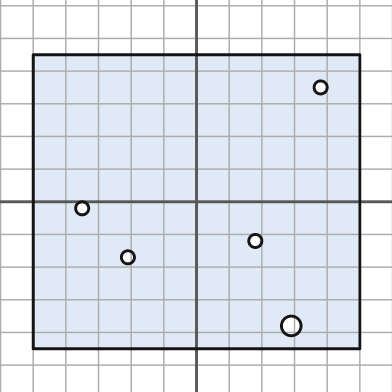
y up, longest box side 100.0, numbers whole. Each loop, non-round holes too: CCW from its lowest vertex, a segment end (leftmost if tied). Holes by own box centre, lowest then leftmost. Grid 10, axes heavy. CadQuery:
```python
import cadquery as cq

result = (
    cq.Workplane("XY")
    .moveTo(-50.0, -45.0)
    .lineTo(50.0, -45.0)
    .lineTo(50.0, 45.0)
    .lineTo(-50.0, 45.0)
    .close()
    .moveTo(29.0, -38.0)
    .circle(3.0)
    .moveTo(-21.0, -17.0)
    .circle(2.0)
    .moveTo(18.0, -12.0)
    .circle(2.0)
    .moveTo(-35.0, -2.0)
    .circle(2.0)
    .moveTo(38.0, 35.0)
    .circle(2.0)
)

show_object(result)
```